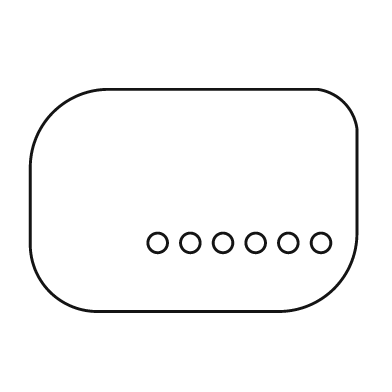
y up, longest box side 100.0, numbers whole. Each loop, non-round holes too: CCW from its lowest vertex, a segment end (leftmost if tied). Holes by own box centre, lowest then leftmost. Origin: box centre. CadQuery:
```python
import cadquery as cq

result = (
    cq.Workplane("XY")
    .moveTo(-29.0, -34.0)
    .lineTo(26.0, -34.0)
    .threePointArc((43.0, -27.0), (50.0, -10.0))
    .lineTo(50.0, 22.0)
    .threePointArc((46.0, 30.0), (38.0, 34.0))
    .lineTo(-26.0, 34.0)
    .threePointArc((-43.0, 27.0), (-50.0, 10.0))
    .lineTo(-50.0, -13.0)
    .threePointArc((-44.0, -28.0), (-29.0, -34.0))
    .close()
    .moveTo(-11.0, -13.0)
    .circle(3.0)
    .moveTo(-1.0, -13.0)
    .circle(3.0)
    .moveTo(9.0, -13.0)
    .circle(3.0)
    .moveTo(19.0, -13.0)
    .circle(3.0)
    .moveTo(29.0, -13.0)
    .circle(3.0)
    .moveTo(39.0, -13.0)
    .circle(3.0)
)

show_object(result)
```